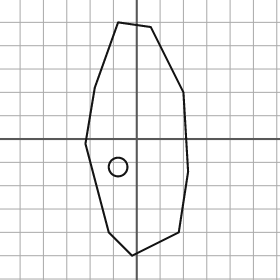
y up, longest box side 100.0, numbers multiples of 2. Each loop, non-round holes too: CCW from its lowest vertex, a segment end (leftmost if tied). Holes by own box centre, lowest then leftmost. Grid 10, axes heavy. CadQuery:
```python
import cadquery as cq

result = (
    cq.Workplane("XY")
    .moveTo(-2.0, -50.0)
    .lineTo(18.0, -40.0)
    .lineTo(22.0, -14.0)
    .lineTo(20.0, 20.0)
    .lineTo(6.0, 48.0)
    .lineTo(-8.0, 50.0)
    .lineTo(-18.0, 22.0)
    .lineTo(-22.0, -2.0)
    .lineTo(-12.0, -40.0)
    .close()
    .moveTo(-8.0, -12.0)
    .circle(4.0)
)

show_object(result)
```